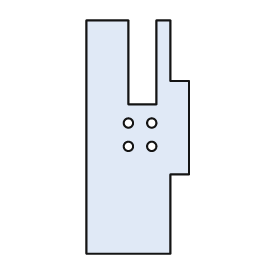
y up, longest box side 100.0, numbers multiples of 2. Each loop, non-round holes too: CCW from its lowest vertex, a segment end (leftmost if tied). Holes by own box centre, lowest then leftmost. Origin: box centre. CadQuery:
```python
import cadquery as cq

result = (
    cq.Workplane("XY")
    .moveTo(-22.0, -50.0)
    .lineTo(14.0, -50.0)
    .lineTo(14.0, -16.0)
    .lineTo(22.0, -16.0)
    .lineTo(22.0, 24.0)
    .lineTo(14.0, 24.0)
    .lineTo(14.0, 50.0)
    .lineTo(8.0, 50.0)
    .lineTo(8.0, 14.0)
    .lineTo(-4.0, 14.0)
    .lineTo(-4.0, 50.0)
    .lineTo(-22.0, 50.0)
    .close()
    .moveTo(-4.0, -4.0)
    .circle(2.0)
    .moveTo(6.0, -4.0)
    .circle(2.0)
    .moveTo(-4.0, 6.0)
    .circle(2.0)
    .moveTo(6.0, 6.0)
    .circle(2.0)
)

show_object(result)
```